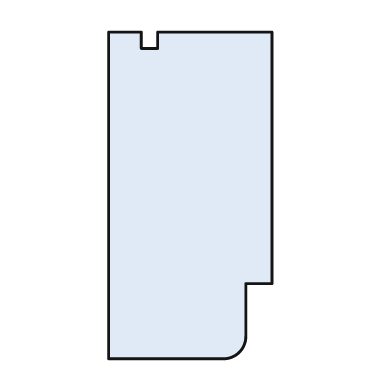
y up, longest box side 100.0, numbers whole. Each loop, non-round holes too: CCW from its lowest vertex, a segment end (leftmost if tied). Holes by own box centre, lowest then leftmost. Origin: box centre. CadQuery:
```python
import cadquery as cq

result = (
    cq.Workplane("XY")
    .moveTo(-25.0, -50.0)
    .lineTo(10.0, -50.0)
    .threePointArc((15.0, -48.0), (17.0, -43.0))
    .lineTo(17.0, -27.0)
    .lineTo(25.0, -27.0)
    .lineTo(25.0, 50.0)
    .lineTo(-10.0, 50.0)
    .lineTo(-10.0, 45.0)
    .lineTo(-15.0, 45.0)
    .lineTo(-15.0, 50.0)
    .lineTo(-25.0, 50.0)
    .close()
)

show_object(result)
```